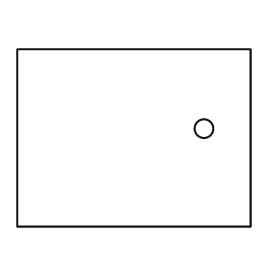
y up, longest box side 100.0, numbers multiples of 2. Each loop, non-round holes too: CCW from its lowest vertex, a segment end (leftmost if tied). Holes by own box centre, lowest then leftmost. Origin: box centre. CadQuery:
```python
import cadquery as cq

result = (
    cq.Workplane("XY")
    .moveTo(-50.0, -38.0)
    .lineTo(50.0, -38.0)
    .lineTo(50.0, 38.0)
    .lineTo(-50.0, 38.0)
    .close()
    .moveTo(30.0, 4.0)
    .circle(4.0)
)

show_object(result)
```